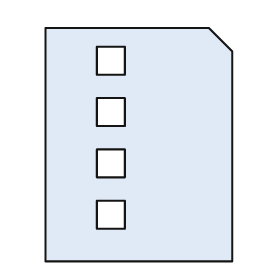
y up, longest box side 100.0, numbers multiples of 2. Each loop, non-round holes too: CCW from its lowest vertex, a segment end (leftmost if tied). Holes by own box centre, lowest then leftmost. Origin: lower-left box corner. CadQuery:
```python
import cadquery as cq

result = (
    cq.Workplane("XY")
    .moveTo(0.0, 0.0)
    .lineTo(80.0, 0.0)
    .lineTo(80.0, 90.0)
    .lineTo(70.0, 100.0)
    .lineTo(0.0, 100.0)
    .close()
    .moveTo(22.0, 14.0)
    .lineTo(34.0, 14.0)
    .lineTo(34.0, 26.0)
    .lineTo(22.0, 26.0)
    .close()
    .moveTo(22.0, 36.0)
    .lineTo(34.0, 36.0)
    .lineTo(34.0, 48.0)
    .lineTo(22.0, 48.0)
    .close()
    .moveTo(22.0, 58.0)
    .lineTo(34.0, 58.0)
    .lineTo(34.0, 70.0)
    .lineTo(22.0, 70.0)
    .close()
    .moveTo(22.0, 80.0)
    .lineTo(34.0, 80.0)
    .lineTo(34.0, 92.0)
    .lineTo(22.0, 92.0)
    .close()
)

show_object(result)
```